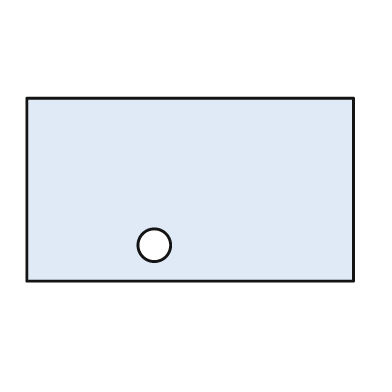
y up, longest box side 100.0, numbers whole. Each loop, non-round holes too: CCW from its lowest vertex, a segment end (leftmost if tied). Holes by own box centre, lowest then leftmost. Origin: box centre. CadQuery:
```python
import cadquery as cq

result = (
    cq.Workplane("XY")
    .moveTo(-50.0, -28.0)
    .lineTo(50.0, -28.0)
    .lineTo(50.0, 28.0)
    .lineTo(-50.0, 28.0)
    .close()
    .moveTo(-11.0, -17.0)
    .circle(5.0)
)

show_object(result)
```